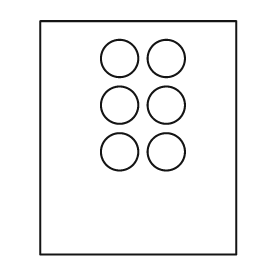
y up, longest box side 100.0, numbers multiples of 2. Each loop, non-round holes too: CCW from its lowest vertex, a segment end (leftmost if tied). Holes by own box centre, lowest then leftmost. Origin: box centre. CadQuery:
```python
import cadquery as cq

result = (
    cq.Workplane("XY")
    .moveTo(-42.0, -50.0)
    .lineTo(42.0, -50.0)
    .lineTo(42.0, 50.0)
    .lineTo(-42.0, 50.0)
    .close()
    .moveTo(-8.0, -6.0)
    .circle(8.0)
    .moveTo(12.0, -6.0)
    .circle(8.0)
    .moveTo(-8.0, 14.0)
    .circle(8.0)
    .moveTo(12.0, 14.0)
    .circle(8.0)
    .moveTo(-8.0, 34.0)
    .circle(8.0)
    .moveTo(12.0, 34.0)
    .circle(8.0)
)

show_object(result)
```